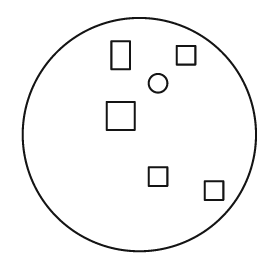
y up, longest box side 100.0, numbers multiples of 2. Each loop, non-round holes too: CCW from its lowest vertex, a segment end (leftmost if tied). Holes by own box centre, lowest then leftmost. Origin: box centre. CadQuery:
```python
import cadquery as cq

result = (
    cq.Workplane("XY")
    .moveTo(0.0, 0.0)
    .circle(50.0)
    .moveTo(28.0, -28.0)
    .lineTo(36.0, -28.0)
    .lineTo(36.0, -20.0)
    .lineTo(28.0, -20.0)
    .close()
    .moveTo(4.0, -22.0)
    .lineTo(12.0, -22.0)
    .lineTo(12.0, -14.0)
    .lineTo(4.0, -14.0)
    .close()
    .moveTo(-14.0, 2.0)
    .lineTo(-2.0, 2.0)
    .lineTo(-2.0, 14.0)
    .lineTo(-14.0, 14.0)
    .close()
    .moveTo(8.0, 22.0)
    .circle(4.0)
    .moveTo(-12.0, 28.0)
    .lineTo(-4.0, 28.0)
    .lineTo(-4.0, 40.0)
    .lineTo(-12.0, 40.0)
    .close()
    .moveTo(16.0, 30.0)
    .lineTo(24.0, 30.0)
    .lineTo(24.0, 38.0)
    .lineTo(16.0, 38.0)
    .close()
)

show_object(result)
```